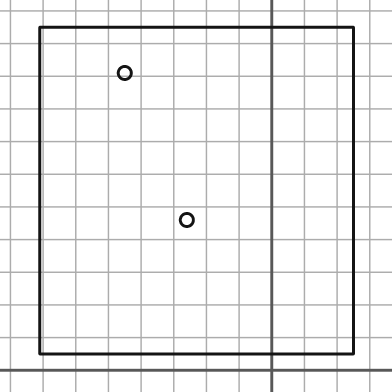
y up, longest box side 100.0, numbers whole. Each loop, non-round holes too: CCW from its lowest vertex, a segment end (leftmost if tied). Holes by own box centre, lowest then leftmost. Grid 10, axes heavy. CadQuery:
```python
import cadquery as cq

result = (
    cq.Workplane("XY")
    .moveTo(-71.0, 5.0)
    .lineTo(25.0, 5.0)
    .lineTo(25.0, 105.0)
    .lineTo(-71.0, 105.0)
    .close()
    .moveTo(-26.0, 46.0)
    .circle(2.0)
    .moveTo(-45.0, 91.0)
    .circle(2.0)
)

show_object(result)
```